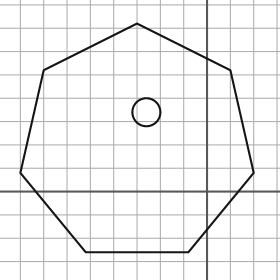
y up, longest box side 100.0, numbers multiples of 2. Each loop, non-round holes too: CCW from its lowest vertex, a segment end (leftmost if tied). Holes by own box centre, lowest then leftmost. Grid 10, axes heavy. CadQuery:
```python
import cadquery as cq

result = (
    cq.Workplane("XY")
    .moveTo(-52.0, -26.0)
    .lineTo(-8.0, -26.0)
    .lineTo(20.0, 8.0)
    .lineTo(10.0, 52.0)
    .lineTo(-30.0, 72.0)
    .lineTo(-70.0, 52.0)
    .lineTo(-80.0, 8.0)
    .close()
    .moveTo(-26.0, 34.0)
    .circle(6.0)
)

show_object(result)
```